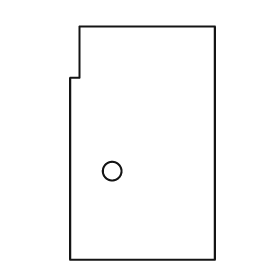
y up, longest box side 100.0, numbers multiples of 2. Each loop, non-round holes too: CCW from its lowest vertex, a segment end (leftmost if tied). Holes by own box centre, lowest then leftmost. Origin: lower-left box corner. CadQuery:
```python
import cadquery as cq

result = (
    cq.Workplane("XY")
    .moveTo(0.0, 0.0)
    .lineTo(62.0, 0.0)
    .lineTo(62.0, 100.0)
    .lineTo(4.0, 100.0)
    .lineTo(4.0, 78.0)
    .lineTo(0.0, 78.0)
    .close()
    .moveTo(18.0, 38.0)
    .circle(4.0)
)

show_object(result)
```